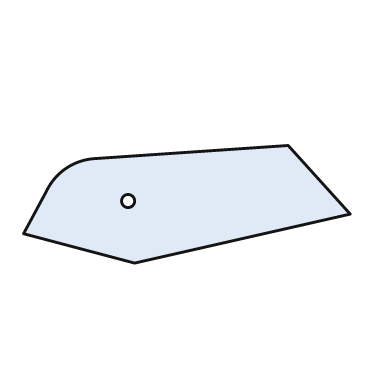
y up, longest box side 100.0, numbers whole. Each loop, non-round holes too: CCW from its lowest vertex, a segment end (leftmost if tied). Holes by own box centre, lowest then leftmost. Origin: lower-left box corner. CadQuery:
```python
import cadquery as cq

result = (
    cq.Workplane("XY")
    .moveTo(34.0, 0.0)
    .lineTo(100.0, 15.0)
    .lineTo(81.0, 36.0)
    .lineTo(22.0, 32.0)
    .threePointArc((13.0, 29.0), (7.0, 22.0))
    .lineTo(0.0, 9.0)
    .close()
    .moveTo(32.0, 19.0)
    .circle(2.0)
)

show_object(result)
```